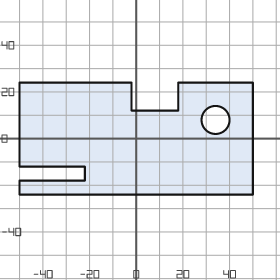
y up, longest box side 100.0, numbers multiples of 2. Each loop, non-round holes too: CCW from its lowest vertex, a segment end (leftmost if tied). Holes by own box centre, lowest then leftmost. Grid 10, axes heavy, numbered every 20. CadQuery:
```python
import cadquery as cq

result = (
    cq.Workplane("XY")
    .moveTo(-50.0, -24.0)
    .lineTo(50.0, -24.0)
    .lineTo(50.0, 24.0)
    .lineTo(18.0, 24.0)
    .lineTo(18.0, 12.0)
    .lineTo(-2.0, 12.0)
    .lineTo(-2.0, 24.0)
    .lineTo(-50.0, 24.0)
    .lineTo(-50.0, -12.0)
    .lineTo(-22.0, -12.0)
    .lineTo(-22.0, -18.0)
    .lineTo(-50.0, -18.0)
    .close()
    .moveTo(34.0, 8.0)
    .circle(6.0)
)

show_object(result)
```